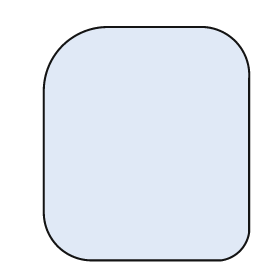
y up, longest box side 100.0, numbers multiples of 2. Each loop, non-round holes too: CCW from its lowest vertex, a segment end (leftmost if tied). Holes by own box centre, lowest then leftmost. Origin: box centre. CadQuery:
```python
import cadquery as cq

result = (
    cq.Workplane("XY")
    .moveTo(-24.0, -50.0)
    .lineTo(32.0, -50.0)
    .threePointArc((40.0, -46.0), (44.0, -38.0))
    .lineTo(44.0, 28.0)
    .threePointArc((38.0, 44.0), (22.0, 50.0))
    .lineTo(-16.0, 50.0)
    .threePointArc((-36.0, 42.0), (-44.0, 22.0))
    .lineTo(-44.0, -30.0)
    .threePointArc((-38.0, -44.0), (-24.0, -50.0))
    .close()
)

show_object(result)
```